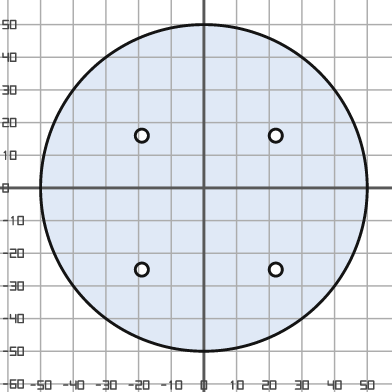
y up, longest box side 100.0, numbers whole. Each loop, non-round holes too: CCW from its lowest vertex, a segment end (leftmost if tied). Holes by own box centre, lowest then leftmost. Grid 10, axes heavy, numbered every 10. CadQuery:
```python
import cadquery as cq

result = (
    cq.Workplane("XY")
    .moveTo(0.0, 0.0)
    .circle(50.0)
    .moveTo(-19.0, -25.0)
    .circle(2.0)
    .moveTo(22.0, -25.0)
    .circle(2.0)
    .moveTo(-19.0, 16.0)
    .circle(2.0)
    .moveTo(22.0, 16.0)
    .circle(2.0)
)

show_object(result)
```